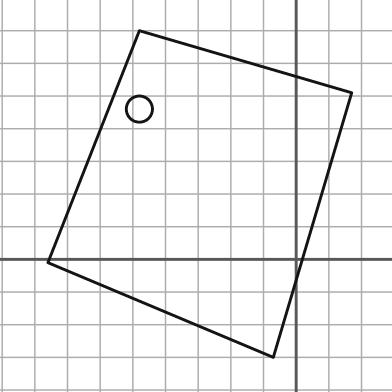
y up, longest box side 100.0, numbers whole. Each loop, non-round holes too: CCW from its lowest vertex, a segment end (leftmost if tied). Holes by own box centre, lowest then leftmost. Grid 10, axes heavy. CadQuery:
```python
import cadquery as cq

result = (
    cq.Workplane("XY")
    .moveTo(-7.0, -30.0)
    .lineTo(17.0, 51.0)
    .lineTo(-48.0, 70.0)
    .lineTo(-76.0, -1.0)
    .close()
    .moveTo(-48.0, 46.0)
    .circle(4.0)
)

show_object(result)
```